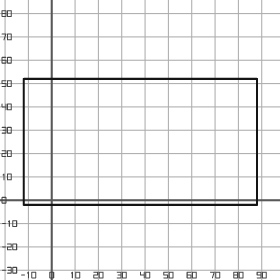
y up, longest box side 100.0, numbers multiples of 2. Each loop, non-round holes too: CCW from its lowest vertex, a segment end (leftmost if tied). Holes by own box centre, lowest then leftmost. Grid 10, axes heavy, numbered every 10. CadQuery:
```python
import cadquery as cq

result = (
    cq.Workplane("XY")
    .moveTo(-12.0, -2.0)
    .lineTo(88.0, -2.0)
    .lineTo(88.0, 52.0)
    .lineTo(-12.0, 52.0)
    .close()
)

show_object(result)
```